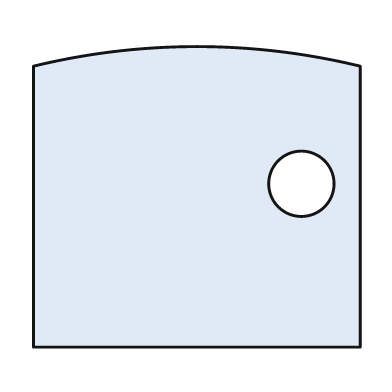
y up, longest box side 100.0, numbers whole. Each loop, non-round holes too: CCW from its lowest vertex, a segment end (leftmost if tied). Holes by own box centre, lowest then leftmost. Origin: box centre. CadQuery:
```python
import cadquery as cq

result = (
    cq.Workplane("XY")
    .moveTo(-50.0, -46.0)
    .lineTo(50.0, -46.0)
    .lineTo(50.0, 40.0)
    .threePointArc((0.0, 46.0), (-50.0, 40.0))
    .close()
    .moveTo(32.0, 4.0)
    .circle(10.0)
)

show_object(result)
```